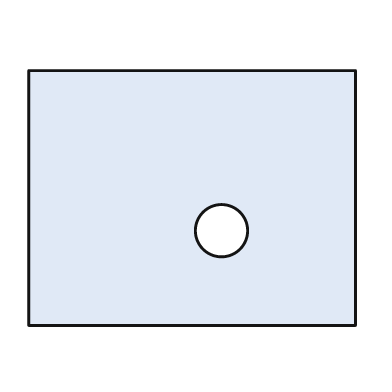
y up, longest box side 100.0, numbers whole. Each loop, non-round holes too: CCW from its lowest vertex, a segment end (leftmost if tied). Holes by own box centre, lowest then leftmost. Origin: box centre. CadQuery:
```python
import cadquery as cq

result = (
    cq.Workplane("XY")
    .moveTo(-50.0, -39.0)
    .lineTo(50.0, -39.0)
    .lineTo(50.0, 39.0)
    .lineTo(-50.0, 39.0)
    .close()
    .moveTo(9.0, -10.0)
    .circle(8.0)
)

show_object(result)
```